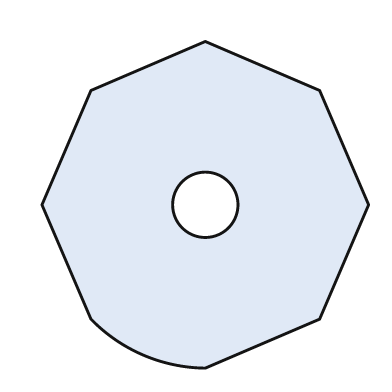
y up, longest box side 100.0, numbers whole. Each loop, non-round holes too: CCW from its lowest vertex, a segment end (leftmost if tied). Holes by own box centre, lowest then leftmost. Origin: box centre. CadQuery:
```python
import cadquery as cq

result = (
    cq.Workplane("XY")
    .moveTo(0.0, -50.0)
    .lineTo(35.0, -35.0)
    .lineTo(50.0, 0.0)
    .lineTo(35.0, 35.0)
    .lineTo(0.0, 50.0)
    .lineTo(-35.0, 35.0)
    .lineTo(-50.0, 0.0)
    .lineTo(-35.0, -35.0)
    .threePointArc((-19.0, -46.0), (0.0, -50.0))
    .close()
    .moveTo(0.0, 0.0)
    .circle(10.0)
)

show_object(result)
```